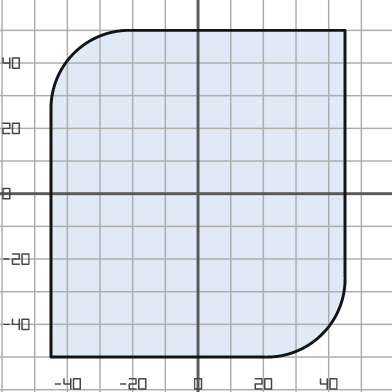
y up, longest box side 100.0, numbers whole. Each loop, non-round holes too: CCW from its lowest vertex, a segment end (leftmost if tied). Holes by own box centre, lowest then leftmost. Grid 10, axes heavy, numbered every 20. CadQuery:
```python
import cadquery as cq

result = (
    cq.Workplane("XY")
    .moveTo(-45.0, -50.0)
    .lineTo(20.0, -50.0)
    .threePointArc((38.0, -43.0), (45.0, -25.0))
    .lineTo(45.0, 50.0)
    .lineTo(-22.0, 50.0)
    .threePointArc((-38.0, 43.0), (-45.0, 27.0))
    .close()
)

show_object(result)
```